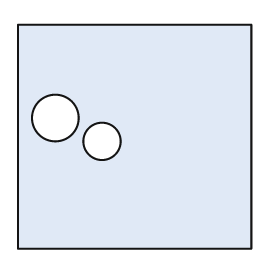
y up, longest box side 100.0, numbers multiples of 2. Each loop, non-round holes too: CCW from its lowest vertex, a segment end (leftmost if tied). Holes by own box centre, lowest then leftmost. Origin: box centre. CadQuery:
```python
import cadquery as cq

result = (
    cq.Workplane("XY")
    .moveTo(-50.0, -48.0)
    .lineTo(50.0, -48.0)
    .lineTo(50.0, 48.0)
    .lineTo(-50.0, 48.0)
    .close()
    .moveTo(-14.0, -2.0)
    .circle(8.0)
    .moveTo(-34.0, 8.0)
    .circle(10.0)
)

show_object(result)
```